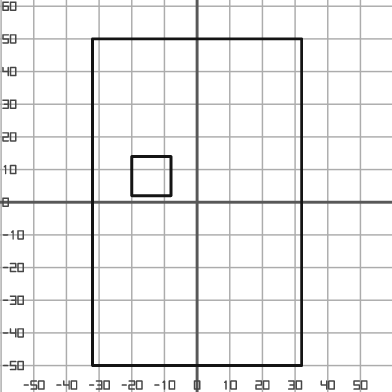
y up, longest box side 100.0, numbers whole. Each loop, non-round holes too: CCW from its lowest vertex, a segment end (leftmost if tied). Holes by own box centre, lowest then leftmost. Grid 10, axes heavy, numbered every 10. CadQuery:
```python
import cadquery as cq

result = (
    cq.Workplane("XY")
    .moveTo(-32.0, -50.0)
    .lineTo(32.0, -50.0)
    .lineTo(32.0, 50.0)
    .lineTo(-32.0, 50.0)
    .close()
    .moveTo(-20.0, 2.0)
    .lineTo(-8.0, 2.0)
    .lineTo(-8.0, 14.0)
    .lineTo(-20.0, 14.0)
    .close()
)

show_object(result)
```